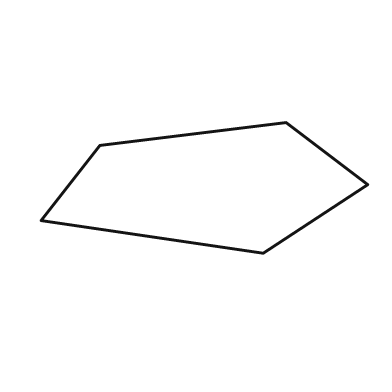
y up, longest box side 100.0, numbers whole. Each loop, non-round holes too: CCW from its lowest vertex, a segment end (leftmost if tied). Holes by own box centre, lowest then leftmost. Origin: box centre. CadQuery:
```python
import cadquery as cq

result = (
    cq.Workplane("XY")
    .moveTo(18.0, -20.0)
    .lineTo(50.0, 1.0)
    .lineTo(25.0, 20.0)
    .lineTo(-32.0, 13.0)
    .lineTo(-50.0, -10.0)
    .close()
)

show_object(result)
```